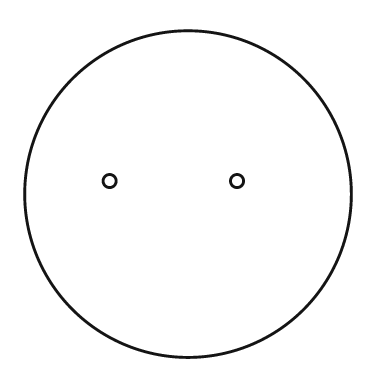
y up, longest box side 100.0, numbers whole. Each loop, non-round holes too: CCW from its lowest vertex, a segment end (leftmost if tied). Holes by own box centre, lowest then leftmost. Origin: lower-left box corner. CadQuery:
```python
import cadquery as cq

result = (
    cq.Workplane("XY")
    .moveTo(50.0, 50.0)
    .circle(50.0)
    .moveTo(26.0, 54.0)
    .circle(2.0)
    .moveTo(65.0, 54.0)
    .circle(2.0)
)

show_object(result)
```